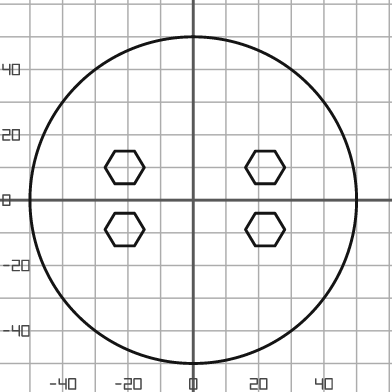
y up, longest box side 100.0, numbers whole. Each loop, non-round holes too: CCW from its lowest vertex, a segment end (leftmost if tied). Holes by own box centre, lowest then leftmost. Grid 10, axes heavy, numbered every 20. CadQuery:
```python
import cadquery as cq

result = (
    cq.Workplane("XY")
    .moveTo(0.0, 0.0)
    .circle(50.0)
    .moveTo(-24.0, -14.0)
    .lineTo(-18.0, -14.0)
    .lineTo(-15.0, -9.0)
    .lineTo(-18.0, -4.0)
    .lineTo(-24.0, -4.0)
    .lineTo(-27.0, -9.0)
    .close()
    .moveTo(19.0, -14.0)
    .lineTo(25.0, -14.0)
    .lineTo(28.0, -9.0)
    .lineTo(25.0, -4.0)
    .lineTo(19.0, -4.0)
    .lineTo(16.0, -9.0)
    .close()
    .moveTo(-24.0, 5.0)
    .lineTo(-18.0, 5.0)
    .lineTo(-15.0, 10.0)
    .lineTo(-18.0, 15.0)
    .lineTo(-24.0, 15.0)
    .lineTo(-27.0, 10.0)
    .close()
    .moveTo(19.0, 5.0)
    .lineTo(25.0, 5.0)
    .lineTo(28.0, 10.0)
    .lineTo(25.0, 15.0)
    .lineTo(19.0, 15.0)
    .lineTo(16.0, 10.0)
    .close()
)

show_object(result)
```